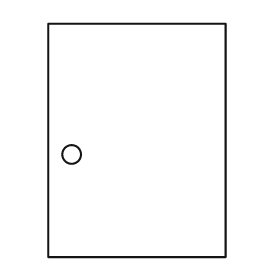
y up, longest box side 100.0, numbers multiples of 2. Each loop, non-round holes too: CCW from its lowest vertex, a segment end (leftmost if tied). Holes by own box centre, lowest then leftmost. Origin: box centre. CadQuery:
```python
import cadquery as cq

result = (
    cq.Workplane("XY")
    .moveTo(-38.0, -50.0)
    .lineTo(38.0, -50.0)
    .lineTo(38.0, 50.0)
    .lineTo(-38.0, 50.0)
    .close()
    .moveTo(-28.0, -6.0)
    .circle(4.0)
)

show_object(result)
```